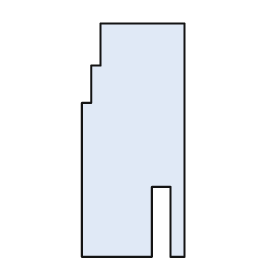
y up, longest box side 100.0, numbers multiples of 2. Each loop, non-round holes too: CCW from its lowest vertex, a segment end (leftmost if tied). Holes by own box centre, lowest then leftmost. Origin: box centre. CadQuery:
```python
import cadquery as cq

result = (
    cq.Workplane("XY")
    .moveTo(-22.0, -50.0)
    .lineTo(8.0, -50.0)
    .lineTo(8.0, -20.0)
    .lineTo(16.0, -20.0)
    .lineTo(16.0, -50.0)
    .lineTo(22.0, -50.0)
    .lineTo(22.0, 50.0)
    .lineTo(-14.0, 50.0)
    .lineTo(-14.0, 32.0)
    .lineTo(-18.0, 32.0)
    .lineTo(-18.0, 16.0)
    .lineTo(-22.0, 16.0)
    .close()
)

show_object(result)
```